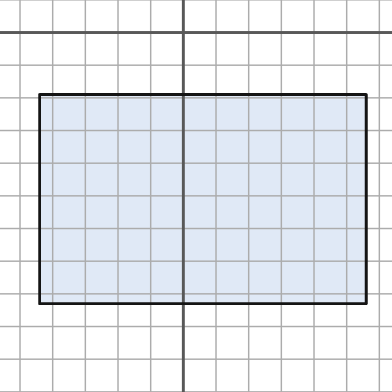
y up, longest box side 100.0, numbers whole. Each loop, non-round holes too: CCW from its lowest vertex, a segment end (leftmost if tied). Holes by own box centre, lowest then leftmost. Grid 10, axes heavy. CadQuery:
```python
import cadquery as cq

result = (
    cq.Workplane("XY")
    .moveTo(-44.0, -83.0)
    .lineTo(56.0, -83.0)
    .lineTo(56.0, -19.0)
    .lineTo(-44.0, -19.0)
    .close()
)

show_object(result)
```